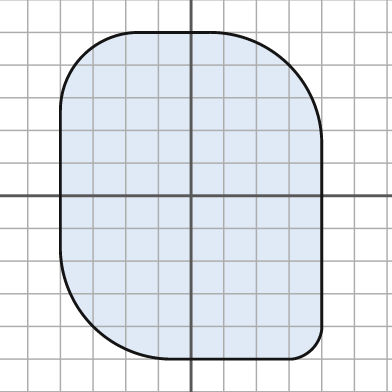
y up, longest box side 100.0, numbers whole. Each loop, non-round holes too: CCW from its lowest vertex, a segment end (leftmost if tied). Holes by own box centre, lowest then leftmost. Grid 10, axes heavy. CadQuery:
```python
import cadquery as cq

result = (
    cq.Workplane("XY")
    .moveTo(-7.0, -50.0)
    .lineTo(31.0, -50.0)
    .threePointArc((37.0, -47.0), (40.0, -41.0))
    .lineTo(40.0, 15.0)
    .threePointArc((30.0, 40.0), (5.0, 50.0))
    .lineTo(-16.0, 50.0)
    .threePointArc((-33.0, 43.0), (-40.0, 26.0))
    .lineTo(-40.0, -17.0)
    .threePointArc((-30.0, -40.0), (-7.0, -50.0))
    .close()
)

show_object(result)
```